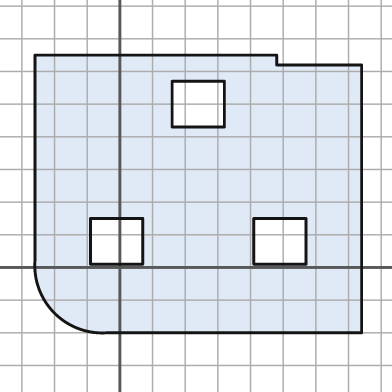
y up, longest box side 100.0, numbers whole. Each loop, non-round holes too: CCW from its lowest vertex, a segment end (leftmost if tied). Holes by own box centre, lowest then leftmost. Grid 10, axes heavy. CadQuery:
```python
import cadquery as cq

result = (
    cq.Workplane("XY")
    .moveTo(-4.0, -20.0)
    .lineTo(74.0, -20.0)
    .lineTo(74.0, 62.0)
    .lineTo(48.0, 62.0)
    .lineTo(48.0, 65.0)
    .lineTo(-26.0, 65.0)
    .lineTo(-26.0, 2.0)
    .threePointArc((-20.0, -14.0), (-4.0, -20.0))
    .close()
    .moveTo(-9.0, 1.0)
    .lineTo(7.0, 1.0)
    .lineTo(7.0, 15.0)
    .lineTo(-9.0, 15.0)
    .close()
    .moveTo(41.0, 1.0)
    .lineTo(57.0, 1.0)
    .lineTo(57.0, 15.0)
    .lineTo(41.0, 15.0)
    .close()
    .moveTo(16.0, 43.0)
    .lineTo(32.0, 43.0)
    .lineTo(32.0, 57.0)
    .lineTo(16.0, 57.0)
    .close()
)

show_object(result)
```